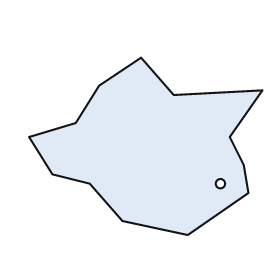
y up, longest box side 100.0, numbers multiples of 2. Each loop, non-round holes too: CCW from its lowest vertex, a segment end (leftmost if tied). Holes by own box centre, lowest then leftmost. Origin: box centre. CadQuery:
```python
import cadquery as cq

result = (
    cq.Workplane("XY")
    .moveTo(18.0, -38.0)
    .lineTo(44.0, -20.0)
    .lineTo(42.0, -8.0)
    .lineTo(36.0, 4.0)
    .lineTo(50.0, 24.0)
    .lineTo(12.0, 22.0)
    .lineTo(-2.0, 38.0)
    .lineTo(-20.0, 26.0)
    .lineTo(-30.0, 10.0)
    .lineTo(-50.0, 4.0)
    .lineTo(-40.0, -12.0)
    .lineTo(-24.0, -16.0)
    .lineTo(-10.0, -32.0)
    .close()
    .moveTo(32.0, -16.0)
    .circle(2.0)
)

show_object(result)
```